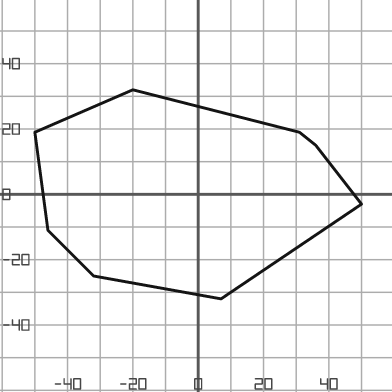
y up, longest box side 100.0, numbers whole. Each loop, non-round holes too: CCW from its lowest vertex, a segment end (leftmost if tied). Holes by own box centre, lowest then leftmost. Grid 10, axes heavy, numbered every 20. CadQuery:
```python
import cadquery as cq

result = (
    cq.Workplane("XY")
    .moveTo(7.0, -32.0)
    .lineTo(50.0, -3.0)
    .lineTo(36.0, 15.0)
    .lineTo(31.0, 19.0)
    .lineTo(-20.0, 32.0)
    .lineTo(-50.0, 19.0)
    .lineTo(-46.0, -11.0)
    .lineTo(-32.0, -25.0)
    .close()
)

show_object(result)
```